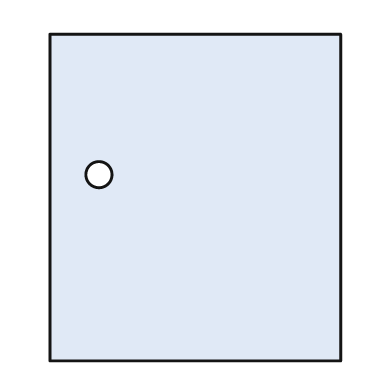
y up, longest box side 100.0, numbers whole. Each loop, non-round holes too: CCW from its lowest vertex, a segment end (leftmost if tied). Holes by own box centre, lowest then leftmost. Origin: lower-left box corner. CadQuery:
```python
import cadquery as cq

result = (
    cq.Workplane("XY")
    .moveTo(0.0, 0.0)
    .lineTo(89.0, 0.0)
    .lineTo(89.0, 100.0)
    .lineTo(0.0, 100.0)
    .close()
    .moveTo(15.0, 57.0)
    .circle(4.0)
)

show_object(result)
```